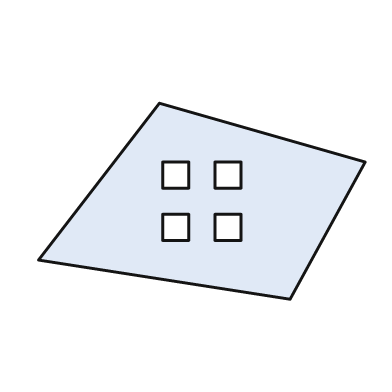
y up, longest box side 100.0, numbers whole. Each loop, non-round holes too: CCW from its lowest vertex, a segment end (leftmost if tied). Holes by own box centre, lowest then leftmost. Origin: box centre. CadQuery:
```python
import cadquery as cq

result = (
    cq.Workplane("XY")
    .moveTo(27.0, -30.0)
    .lineTo(50.0, 12.0)
    .lineTo(-13.0, 30.0)
    .lineTo(-50.0, -18.0)
    .close()
    .moveTo(-12.0, -12.0)
    .lineTo(-4.0, -12.0)
    .lineTo(-4.0, -4.0)
    .lineTo(-12.0, -4.0)
    .close()
    .moveTo(4.0, -12.0)
    .lineTo(12.0, -12.0)
    .lineTo(12.0, -4.0)
    .lineTo(4.0, -4.0)
    .close()
    .moveTo(-12.0, 4.0)
    .lineTo(-4.0, 4.0)
    .lineTo(-4.0, 12.0)
    .lineTo(-12.0, 12.0)
    .close()
    .moveTo(4.0, 4.0)
    .lineTo(12.0, 4.0)
    .lineTo(12.0, 12.0)
    .lineTo(4.0, 12.0)
    .close()
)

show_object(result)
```